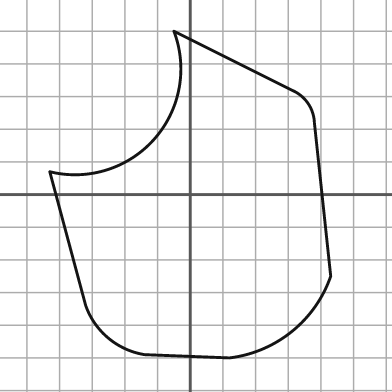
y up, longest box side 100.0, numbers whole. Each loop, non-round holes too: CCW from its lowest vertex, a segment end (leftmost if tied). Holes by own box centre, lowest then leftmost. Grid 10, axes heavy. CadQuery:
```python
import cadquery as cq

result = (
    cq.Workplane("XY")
    .moveTo(12.0, -50.0)
    .threePointArc((31.0, -42.0), (43.0, -25.0))
    .lineTo(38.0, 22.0)
    .threePointArc((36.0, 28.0), (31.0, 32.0))
    .lineTo(-5.0, 50.0)
    .threePointArc((-11.0, 17.0), (-43.0, 7.0))
    .lineTo(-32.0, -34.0)
    .threePointArc((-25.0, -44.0), (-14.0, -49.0))
    .close()
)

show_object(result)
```